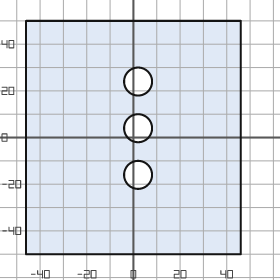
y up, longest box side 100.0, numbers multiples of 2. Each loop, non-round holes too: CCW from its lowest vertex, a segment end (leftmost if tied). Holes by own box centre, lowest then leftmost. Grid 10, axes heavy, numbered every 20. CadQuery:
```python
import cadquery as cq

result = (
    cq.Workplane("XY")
    .moveTo(-46.0, -50.0)
    .lineTo(46.0, -50.0)
    .lineTo(46.0, 50.0)
    .lineTo(-46.0, 50.0)
    .close()
    .moveTo(2.0, -16.0)
    .circle(6.0)
    .moveTo(2.0, 4.0)
    .circle(6.0)
    .moveTo(2.0, 24.0)
    .circle(6.0)
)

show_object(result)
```